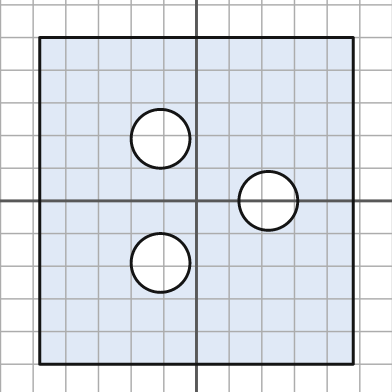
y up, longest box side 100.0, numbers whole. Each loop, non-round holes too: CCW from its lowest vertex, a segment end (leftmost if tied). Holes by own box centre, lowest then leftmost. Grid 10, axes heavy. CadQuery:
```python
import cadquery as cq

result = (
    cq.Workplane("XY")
    .moveTo(-48.0, -50.0)
    .lineTo(48.0, -50.0)
    .lineTo(48.0, 50.0)
    .lineTo(-48.0, 50.0)
    .close()
    .moveTo(-11.0, -19.0)
    .circle(9.0)
    .moveTo(22.0, 0.0)
    .circle(9.0)
    .moveTo(-11.0, 19.0)
    .circle(9.0)
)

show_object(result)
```